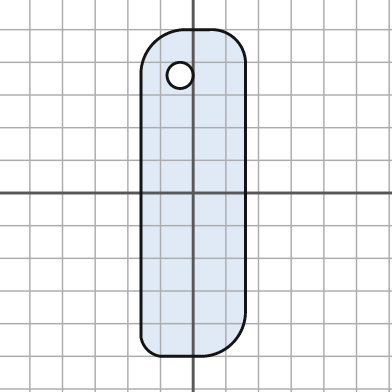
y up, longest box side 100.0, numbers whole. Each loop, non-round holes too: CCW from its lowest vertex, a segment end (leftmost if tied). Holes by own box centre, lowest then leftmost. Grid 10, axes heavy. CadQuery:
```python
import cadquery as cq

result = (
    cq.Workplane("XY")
    .moveTo(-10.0, -50.0)
    .lineTo(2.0, -50.0)
    .threePointArc((12.0, -46.0), (16.0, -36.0))
    .lineTo(16.0, 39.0)
    .threePointArc((13.0, 47.0), (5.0, 50.0))
    .lineTo(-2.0, 50.0)
    .threePointArc((-12.0, 46.0), (-16.0, 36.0))
    .lineTo(-16.0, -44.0)
    .threePointArc((-14.0, -48.0), (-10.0, -50.0))
    .close()
    .moveTo(-4.0, 36.0)
    .circle(4.0)
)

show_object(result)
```